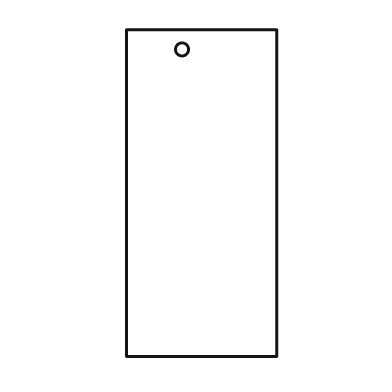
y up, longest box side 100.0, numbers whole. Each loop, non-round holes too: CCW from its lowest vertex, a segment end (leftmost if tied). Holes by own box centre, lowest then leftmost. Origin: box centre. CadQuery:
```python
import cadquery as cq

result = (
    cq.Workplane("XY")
    .moveTo(-23.0, -50.0)
    .lineTo(23.0, -50.0)
    .lineTo(23.0, 50.0)
    .lineTo(-23.0, 50.0)
    .close()
    .moveTo(-6.0, 44.0)
    .circle(2.0)
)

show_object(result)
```